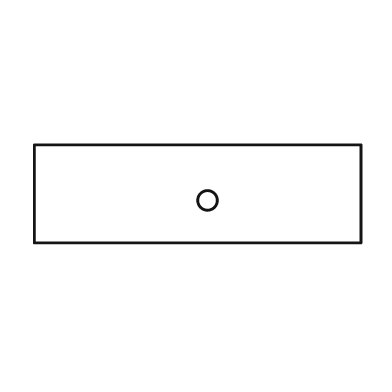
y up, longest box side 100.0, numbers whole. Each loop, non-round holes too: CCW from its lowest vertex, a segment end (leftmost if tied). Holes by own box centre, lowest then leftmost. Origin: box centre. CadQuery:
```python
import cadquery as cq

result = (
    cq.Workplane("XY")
    .moveTo(-50.0, -15.0)
    .lineTo(50.0, -15.0)
    .lineTo(50.0, 15.0)
    .lineTo(-50.0, 15.0)
    .close()
    .moveTo(3.0, -2.0)
    .circle(3.0)
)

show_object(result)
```